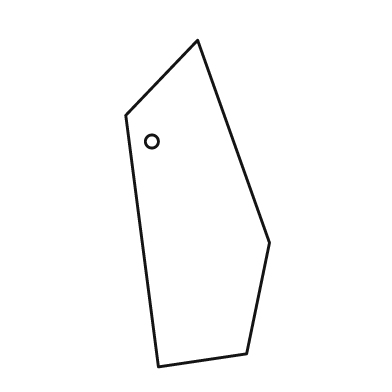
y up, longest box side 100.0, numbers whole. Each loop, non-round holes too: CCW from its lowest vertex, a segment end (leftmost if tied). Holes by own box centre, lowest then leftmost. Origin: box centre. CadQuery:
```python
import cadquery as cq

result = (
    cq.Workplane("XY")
    .moveTo(-12.0, -50.0)
    .lineTo(15.0, -46.0)
    .lineTo(22.0, -12.0)
    .lineTo(0.0, 50.0)
    .lineTo(-22.0, 27.0)
    .close()
    .moveTo(-14.0, 19.0)
    .circle(2.0)
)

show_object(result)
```